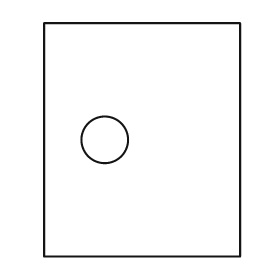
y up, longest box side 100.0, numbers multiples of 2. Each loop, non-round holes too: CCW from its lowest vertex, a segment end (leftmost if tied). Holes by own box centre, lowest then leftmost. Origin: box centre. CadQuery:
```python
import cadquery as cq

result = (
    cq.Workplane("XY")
    .moveTo(-42.0, -50.0)
    .lineTo(42.0, -50.0)
    .lineTo(42.0, 50.0)
    .lineTo(-42.0, 50.0)
    .close()
    .moveTo(-16.0, 0.0)
    .circle(10.0)
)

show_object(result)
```